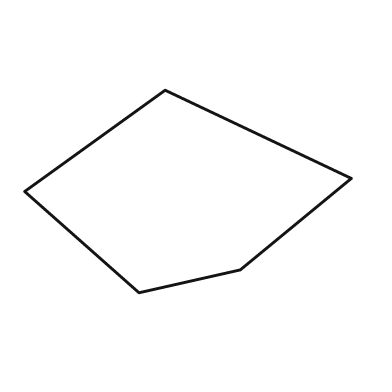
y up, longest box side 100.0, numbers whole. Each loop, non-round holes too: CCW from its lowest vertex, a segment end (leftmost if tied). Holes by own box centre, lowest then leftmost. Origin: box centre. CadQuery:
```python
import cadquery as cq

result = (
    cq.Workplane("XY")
    .moveTo(-15.0, -31.0)
    .lineTo(16.0, -24.0)
    .lineTo(50.0, 4.0)
    .lineTo(-7.0, 31.0)
    .lineTo(-50.0, 0.0)
    .close()
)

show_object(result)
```